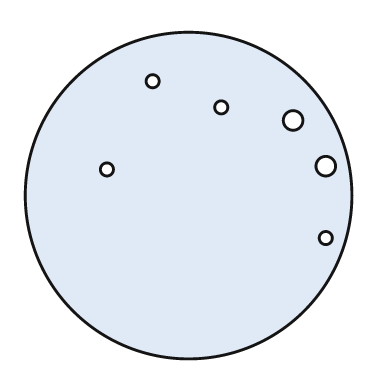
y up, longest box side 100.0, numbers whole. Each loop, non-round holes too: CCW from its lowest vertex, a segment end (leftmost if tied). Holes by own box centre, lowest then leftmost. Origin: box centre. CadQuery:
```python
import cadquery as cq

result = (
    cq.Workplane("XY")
    .moveTo(0.0, 0.0)
    .circle(50.0)
    .moveTo(42.0, -13.0)
    .circle(2.0)
    .moveTo(-25.0, 8.0)
    .circle(2.0)
    .moveTo(42.0, 9.0)
    .circle(3.0)
    .moveTo(32.0, 23.0)
    .circle(3.0)
    .moveTo(10.0, 27.0)
    .circle(2.0)
    .moveTo(-11.0, 35.0)
    .circle(2.0)
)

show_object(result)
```